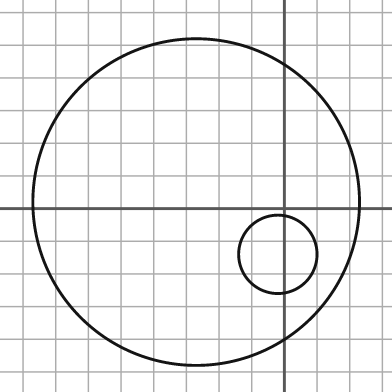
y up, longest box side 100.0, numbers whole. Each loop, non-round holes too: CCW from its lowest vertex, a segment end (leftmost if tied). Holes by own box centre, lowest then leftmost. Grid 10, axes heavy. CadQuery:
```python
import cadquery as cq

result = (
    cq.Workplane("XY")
    .moveTo(-27.0, 2.0)
    .circle(50.0)
    .moveTo(-2.0, -14.0)
    .circle(12.0)
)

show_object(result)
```